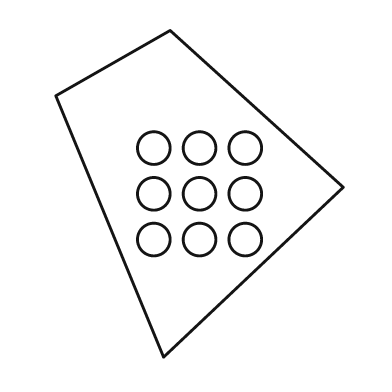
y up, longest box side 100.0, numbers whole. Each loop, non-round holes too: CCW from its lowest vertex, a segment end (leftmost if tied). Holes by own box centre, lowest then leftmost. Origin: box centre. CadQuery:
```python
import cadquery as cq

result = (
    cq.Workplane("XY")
    .moveTo(-11.0, -50.0)
    .lineTo(44.0, 2.0)
    .lineTo(-9.0, 50.0)
    .lineTo(-44.0, 30.0)
    .close()
    .moveTo(-14.0, -14.0)
    .circle(5.0)
    .moveTo(0.0, -14.0)
    .circle(5.0)
    .moveTo(14.0, -14.0)
    .circle(5.0)
    .moveTo(-14.0, 0.0)
    .circle(5.0)
    .moveTo(0.0, 0.0)
    .circle(5.0)
    .moveTo(14.0, 0.0)
    .circle(5.0)
    .moveTo(-14.0, 14.0)
    .circle(5.0)
    .moveTo(0.0, 14.0)
    .circle(5.0)
    .moveTo(14.0, 14.0)
    .circle(5.0)
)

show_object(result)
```